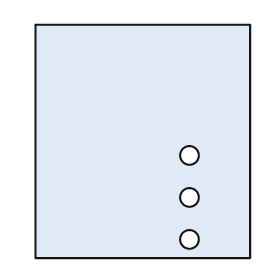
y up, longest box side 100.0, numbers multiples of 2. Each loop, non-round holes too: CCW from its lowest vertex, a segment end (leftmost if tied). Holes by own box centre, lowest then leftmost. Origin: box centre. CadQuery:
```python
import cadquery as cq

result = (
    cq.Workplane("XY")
    .moveTo(-46.0, -50.0)
    .lineTo(46.0, -50.0)
    .lineTo(46.0, 50.0)
    .lineTo(-46.0, 50.0)
    .close()
    .moveTo(20.0, -42.0)
    .circle(4.0)
    .moveTo(20.0, -24.0)
    .circle(4.0)
    .moveTo(20.0, -6.0)
    .circle(4.0)
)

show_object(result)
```